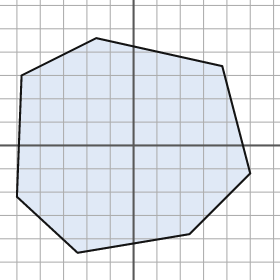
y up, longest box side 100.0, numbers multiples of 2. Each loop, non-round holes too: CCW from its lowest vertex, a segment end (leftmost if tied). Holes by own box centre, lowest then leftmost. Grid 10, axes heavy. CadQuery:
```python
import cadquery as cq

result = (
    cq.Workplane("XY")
    .moveTo(-24.0, -46.0)
    .lineTo(24.0, -38.0)
    .lineTo(50.0, -12.0)
    .lineTo(38.0, 34.0)
    .lineTo(-16.0, 46.0)
    .lineTo(-48.0, 30.0)
    .lineTo(-50.0, -22.0)
    .close()
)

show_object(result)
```